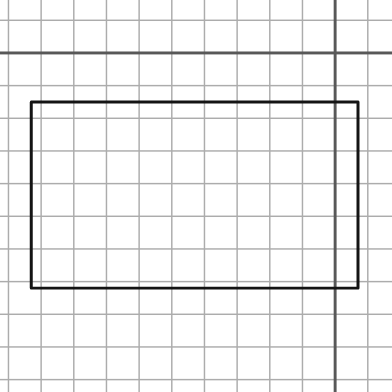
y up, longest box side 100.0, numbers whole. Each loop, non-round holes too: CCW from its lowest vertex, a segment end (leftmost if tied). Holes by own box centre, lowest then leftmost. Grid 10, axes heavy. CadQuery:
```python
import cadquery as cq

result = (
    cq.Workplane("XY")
    .moveTo(-93.0, -72.0)
    .lineTo(7.0, -72.0)
    .lineTo(7.0, -15.0)
    .lineTo(-93.0, -15.0)
    .close()
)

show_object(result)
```